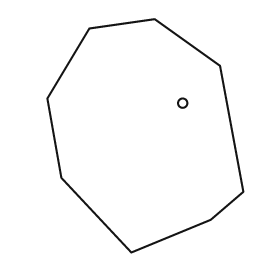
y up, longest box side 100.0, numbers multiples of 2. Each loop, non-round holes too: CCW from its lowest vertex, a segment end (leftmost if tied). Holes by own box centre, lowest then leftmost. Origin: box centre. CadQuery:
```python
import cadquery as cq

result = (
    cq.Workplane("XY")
    .moveTo(-6.0, -50.0)
    .lineTo(28.0, -36.0)
    .lineTo(42.0, -24.0)
    .lineTo(32.0, 30.0)
    .lineTo(4.0, 50.0)
    .lineTo(-24.0, 46.0)
    .lineTo(-42.0, 16.0)
    .lineTo(-36.0, -18.0)
    .close()
    .moveTo(16.0, 14.0)
    .circle(2.0)
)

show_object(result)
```